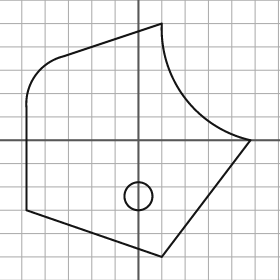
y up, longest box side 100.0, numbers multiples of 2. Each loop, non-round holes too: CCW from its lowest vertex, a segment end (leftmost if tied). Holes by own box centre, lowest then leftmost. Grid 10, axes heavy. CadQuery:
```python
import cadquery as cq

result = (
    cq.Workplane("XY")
    .moveTo(10.0, -50.0)
    .lineTo(48.0, 0.0)
    .threePointArc((20.0, 18.0), (10.0, 50.0))
    .lineTo(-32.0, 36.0)
    .threePointArc((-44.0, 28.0), (-48.0, 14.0))
    .lineTo(-48.0, -30.0)
    .close()
    .moveTo(0.0, -24.0)
    .circle(6.0)
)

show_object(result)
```